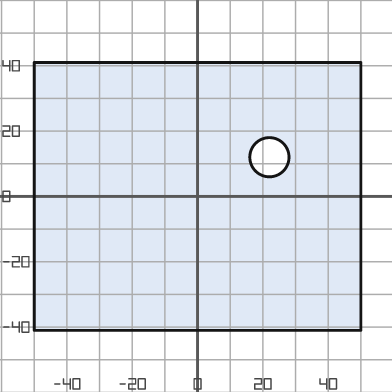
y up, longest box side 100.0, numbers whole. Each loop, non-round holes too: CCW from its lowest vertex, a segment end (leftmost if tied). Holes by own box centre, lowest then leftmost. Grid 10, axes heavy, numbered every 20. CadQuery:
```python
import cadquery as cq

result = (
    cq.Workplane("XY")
    .moveTo(-50.0, -41.0)
    .lineTo(50.0, -41.0)
    .lineTo(50.0, 41.0)
    .lineTo(-50.0, 41.0)
    .close()
    .moveTo(22.0, 12.0)
    .circle(6.0)
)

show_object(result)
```